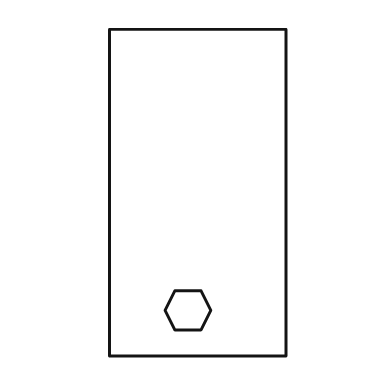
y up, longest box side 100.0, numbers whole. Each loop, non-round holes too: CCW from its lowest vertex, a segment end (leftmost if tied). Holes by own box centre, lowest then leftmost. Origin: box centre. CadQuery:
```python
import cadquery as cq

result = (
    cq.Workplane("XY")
    .moveTo(-27.0, -50.0)
    .lineTo(27.0, -50.0)
    .lineTo(27.0, 50.0)
    .lineTo(-27.0, 50.0)
    .close()
    .moveTo(-7.0, -42.0)
    .lineTo(1.0, -42.0)
    .lineTo(4.0, -36.0)
    .lineTo(1.0, -30.0)
    .lineTo(-7.0, -30.0)
    .lineTo(-10.0, -36.0)
    .close()
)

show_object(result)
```